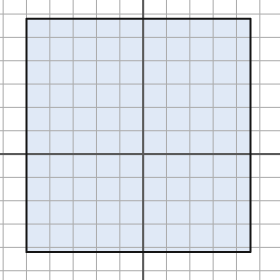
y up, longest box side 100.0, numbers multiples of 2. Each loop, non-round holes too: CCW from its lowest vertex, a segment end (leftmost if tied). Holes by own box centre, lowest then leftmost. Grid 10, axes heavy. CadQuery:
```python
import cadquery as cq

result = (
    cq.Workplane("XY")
    .moveTo(-50.0, -42.0)
    .lineTo(46.0, -42.0)
    .lineTo(46.0, 58.0)
    .lineTo(-50.0, 58.0)
    .close()
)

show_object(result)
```